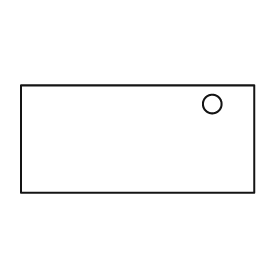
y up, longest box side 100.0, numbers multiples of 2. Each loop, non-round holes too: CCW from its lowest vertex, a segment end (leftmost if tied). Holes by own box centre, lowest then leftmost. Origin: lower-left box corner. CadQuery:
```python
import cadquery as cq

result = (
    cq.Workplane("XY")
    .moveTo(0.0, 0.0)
    .lineTo(100.0, 0.0)
    .lineTo(100.0, 46.0)
    .lineTo(0.0, 46.0)
    .close()
    .moveTo(82.0, 38.0)
    .circle(4.0)
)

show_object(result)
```